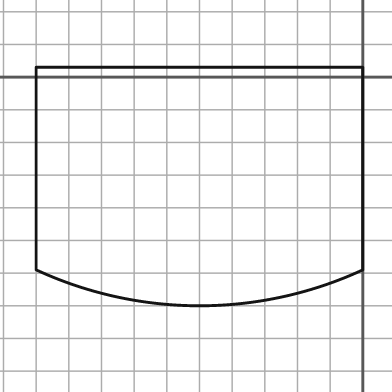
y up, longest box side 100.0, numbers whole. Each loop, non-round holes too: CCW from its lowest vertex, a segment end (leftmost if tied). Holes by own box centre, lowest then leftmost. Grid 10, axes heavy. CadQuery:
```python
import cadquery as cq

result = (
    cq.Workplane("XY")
    .moveTo(-100.0, -59.0)
    .threePointArc((-50.0, -70.0), (0.0, -59.0))
    .lineTo(0.0, 3.0)
    .lineTo(-100.0, 3.0)
    .close()
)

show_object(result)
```